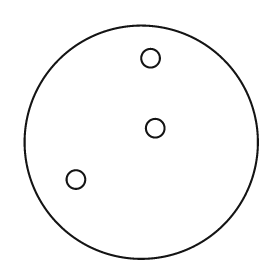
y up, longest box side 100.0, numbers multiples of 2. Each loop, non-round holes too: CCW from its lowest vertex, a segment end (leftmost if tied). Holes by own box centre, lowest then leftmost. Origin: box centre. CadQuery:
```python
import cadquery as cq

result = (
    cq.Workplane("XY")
    .moveTo(0.0, 0.0)
    .circle(50.0)
    .moveTo(-28.0, -16.0)
    .circle(4.0)
    .moveTo(6.0, 6.0)
    .circle(4.0)
    .moveTo(4.0, 36.0)
    .circle(4.0)
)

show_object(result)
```